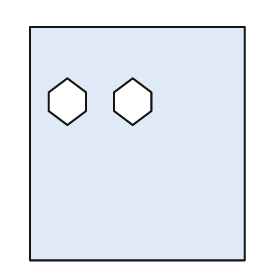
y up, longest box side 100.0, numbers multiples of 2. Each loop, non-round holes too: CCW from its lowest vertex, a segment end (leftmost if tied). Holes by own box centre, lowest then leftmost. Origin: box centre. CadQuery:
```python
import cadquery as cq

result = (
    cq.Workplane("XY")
    .moveTo(-46.0, -50.0)
    .lineTo(46.0, -50.0)
    .lineTo(46.0, 50.0)
    .lineTo(-46.0, 50.0)
    .close()
    .moveTo(-30.0, 8.0)
    .lineTo(-22.0, 14.0)
    .lineTo(-22.0, 22.0)
    .lineTo(-30.0, 28.0)
    .lineTo(-38.0, 22.0)
    .lineTo(-38.0, 14.0)
    .close()
    .moveTo(-2.0, 8.0)
    .lineTo(6.0, 14.0)
    .lineTo(6.0, 22.0)
    .lineTo(-2.0, 28.0)
    .lineTo(-10.0, 22.0)
    .lineTo(-10.0, 14.0)
    .close()
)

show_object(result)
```